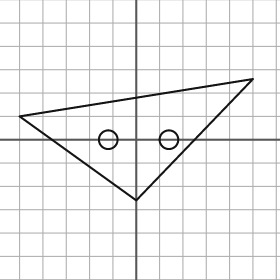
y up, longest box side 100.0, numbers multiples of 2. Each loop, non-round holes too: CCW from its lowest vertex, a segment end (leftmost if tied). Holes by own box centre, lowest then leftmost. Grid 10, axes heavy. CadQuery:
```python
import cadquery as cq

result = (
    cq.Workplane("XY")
    .moveTo(0.0, -26.0)
    .lineTo(50.0, 26.0)
    .lineTo(-50.0, 10.0)
    .close()
    .moveTo(-12.0, 0.0)
    .circle(4.0)
    .moveTo(14.0, 0.0)
    .circle(4.0)
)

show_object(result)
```